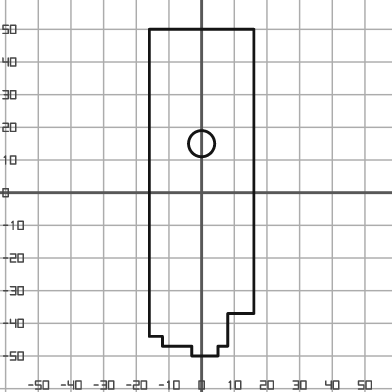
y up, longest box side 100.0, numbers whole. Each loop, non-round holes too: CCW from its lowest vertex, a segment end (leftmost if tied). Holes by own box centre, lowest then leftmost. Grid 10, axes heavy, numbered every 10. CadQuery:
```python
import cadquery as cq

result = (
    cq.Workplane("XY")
    .moveTo(-3.0, -50.0)
    .lineTo(5.0, -50.0)
    .lineTo(5.0, -47.0)
    .lineTo(8.0, -47.0)
    .lineTo(8.0, -37.0)
    .lineTo(16.0, -37.0)
    .lineTo(16.0, 50.0)
    .lineTo(-16.0, 50.0)
    .lineTo(-16.0, -44.0)
    .lineTo(-12.0, -44.0)
    .lineTo(-12.0, -47.0)
    .lineTo(-3.0, -47.0)
    .close()
    .moveTo(0.0, 15.0)
    .circle(4.0)
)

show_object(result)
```